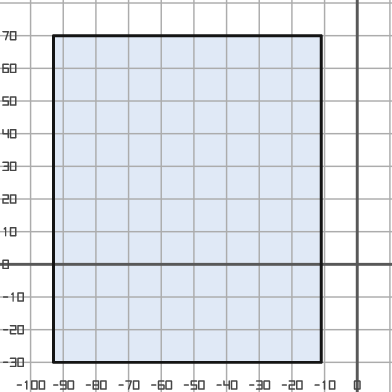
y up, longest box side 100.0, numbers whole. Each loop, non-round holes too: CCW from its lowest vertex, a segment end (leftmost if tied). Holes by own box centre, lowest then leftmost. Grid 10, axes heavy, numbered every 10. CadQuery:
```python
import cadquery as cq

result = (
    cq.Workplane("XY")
    .moveTo(-93.0, -30.0)
    .lineTo(-11.0, -30.0)
    .lineTo(-11.0, 70.0)
    .lineTo(-93.0, 70.0)
    .close()
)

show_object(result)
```